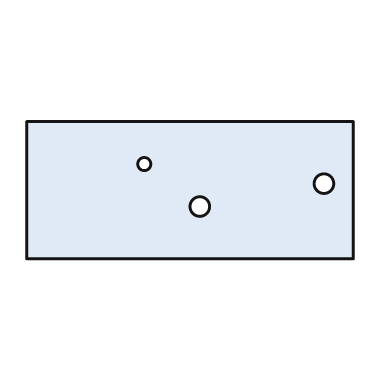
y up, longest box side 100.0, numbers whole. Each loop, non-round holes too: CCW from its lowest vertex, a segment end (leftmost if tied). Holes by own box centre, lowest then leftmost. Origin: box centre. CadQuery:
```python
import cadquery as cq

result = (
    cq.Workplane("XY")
    .moveTo(-50.0, -21.0)
    .lineTo(50.0, -21.0)
    .lineTo(50.0, 21.0)
    .lineTo(-50.0, 21.0)
    .close()
    .moveTo(3.0, -5.0)
    .circle(3.0)
    .moveTo(41.0, 2.0)
    .circle(3.0)
    .moveTo(-14.0, 8.0)
    .circle(2.0)
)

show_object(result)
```